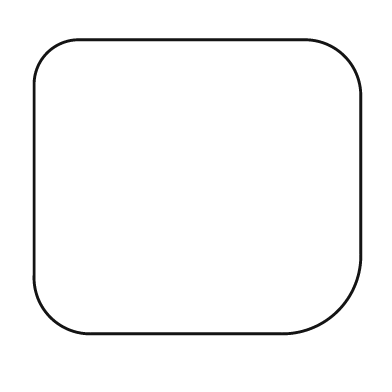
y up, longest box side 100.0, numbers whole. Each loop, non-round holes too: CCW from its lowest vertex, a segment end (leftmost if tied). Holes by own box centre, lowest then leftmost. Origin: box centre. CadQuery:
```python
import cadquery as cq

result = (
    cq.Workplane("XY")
    .moveTo(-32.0, -45.0)
    .lineTo(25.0, -45.0)
    .threePointArc((43.0, -38.0), (50.0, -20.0))
    .lineTo(50.0, 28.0)
    .threePointArc((45.0, 40.0), (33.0, 45.0))
    .lineTo(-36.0, 45.0)
    .threePointArc((-46.0, 41.0), (-50.0, 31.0))
    .lineTo(-50.0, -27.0)
    .threePointArc((-45.0, -40.0), (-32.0, -45.0))
    .close()
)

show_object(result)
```